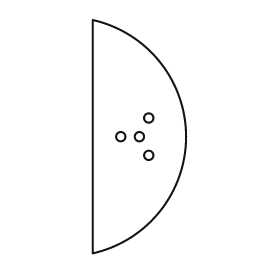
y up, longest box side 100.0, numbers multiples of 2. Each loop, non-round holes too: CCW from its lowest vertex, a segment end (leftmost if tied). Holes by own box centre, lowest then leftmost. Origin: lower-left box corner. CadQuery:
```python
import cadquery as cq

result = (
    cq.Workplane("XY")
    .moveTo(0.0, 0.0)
    .threePointArc((40.0, 50.0), (0.0, 100.0))
    .close()
    .moveTo(24.0, 42.0)
    .circle(2.0)
    .moveTo(12.0, 50.0)
    .circle(2.0)
    .moveTo(20.0, 50.0)
    .circle(2.0)
    .moveTo(24.0, 58.0)
    .circle(2.0)
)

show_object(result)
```